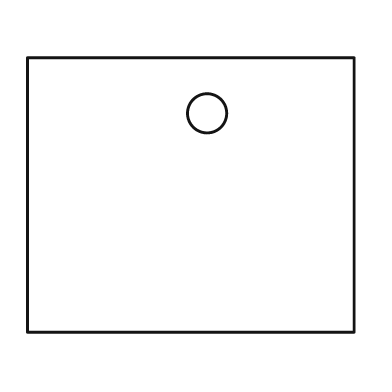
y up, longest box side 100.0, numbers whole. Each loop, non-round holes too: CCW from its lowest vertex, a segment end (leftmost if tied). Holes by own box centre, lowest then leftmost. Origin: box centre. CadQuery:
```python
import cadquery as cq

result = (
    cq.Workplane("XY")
    .moveTo(-50.0, -42.0)
    .lineTo(50.0, -42.0)
    .lineTo(50.0, 42.0)
    .lineTo(-50.0, 42.0)
    .close()
    .moveTo(5.0, 25.0)
    .circle(6.0)
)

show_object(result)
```